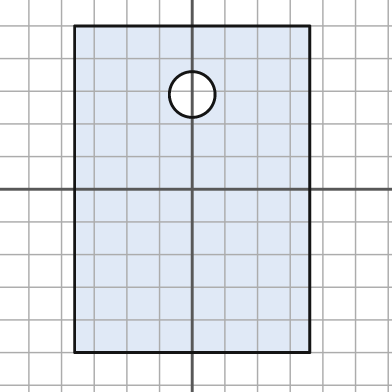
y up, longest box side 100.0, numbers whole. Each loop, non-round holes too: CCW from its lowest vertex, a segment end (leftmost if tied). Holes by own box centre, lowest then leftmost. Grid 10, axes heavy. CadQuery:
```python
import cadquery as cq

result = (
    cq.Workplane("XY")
    .moveTo(-36.0, -50.0)
    .lineTo(36.0, -50.0)
    .lineTo(36.0, 50.0)
    .lineTo(-36.0, 50.0)
    .close()
    .moveTo(0.0, 29.0)
    .circle(7.0)
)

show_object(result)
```